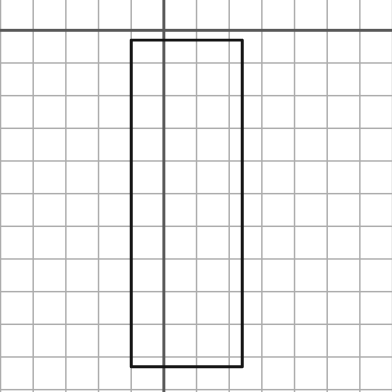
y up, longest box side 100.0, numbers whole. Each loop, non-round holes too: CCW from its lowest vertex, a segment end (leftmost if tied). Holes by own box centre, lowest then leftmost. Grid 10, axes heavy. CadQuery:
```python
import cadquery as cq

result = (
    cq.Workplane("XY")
    .moveTo(-10.0, -103.0)
    .lineTo(24.0, -103.0)
    .lineTo(24.0, -3.0)
    .lineTo(-10.0, -3.0)
    .close()
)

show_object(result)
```